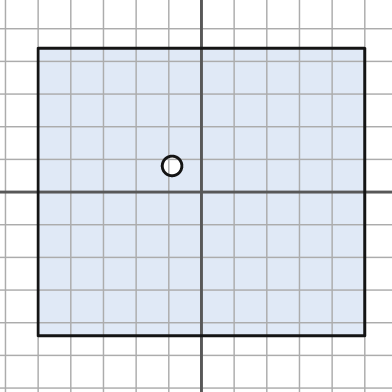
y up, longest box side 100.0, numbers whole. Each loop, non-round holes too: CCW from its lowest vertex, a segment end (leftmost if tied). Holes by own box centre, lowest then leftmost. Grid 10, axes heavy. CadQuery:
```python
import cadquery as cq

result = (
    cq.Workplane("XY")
    .moveTo(-50.0, -44.0)
    .lineTo(50.0, -44.0)
    .lineTo(50.0, 44.0)
    .lineTo(-50.0, 44.0)
    .close()
    .moveTo(-9.0, 8.0)
    .circle(3.0)
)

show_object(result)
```